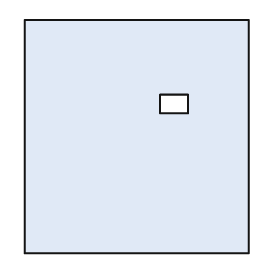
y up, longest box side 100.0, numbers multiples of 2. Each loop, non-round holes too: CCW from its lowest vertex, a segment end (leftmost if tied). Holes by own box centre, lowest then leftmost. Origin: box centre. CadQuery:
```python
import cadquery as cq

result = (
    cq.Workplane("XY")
    .moveTo(-48.0, -50.0)
    .lineTo(48.0, -50.0)
    .lineTo(48.0, 50.0)
    .lineTo(-48.0, 50.0)
    .close()
    .moveTo(10.0, 10.0)
    .lineTo(22.0, 10.0)
    .lineTo(22.0, 18.0)
    .lineTo(10.0, 18.0)
    .close()
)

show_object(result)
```